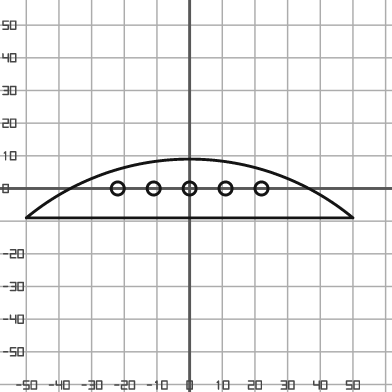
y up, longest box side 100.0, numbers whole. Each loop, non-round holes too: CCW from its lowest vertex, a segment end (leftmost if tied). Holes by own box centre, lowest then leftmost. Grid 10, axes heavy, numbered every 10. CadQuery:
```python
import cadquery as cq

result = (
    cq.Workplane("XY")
    .moveTo(-50.0, -9.0)
    .lineTo(50.0, -9.0)
    .threePointArc((0.0, 9.0), (-50.0, -9.0))
    .close()
    .moveTo(-22.0, 0.0)
    .circle(2.0)
    .moveTo(-11.0, 0.0)
    .circle(2.0)
    .moveTo(0.0, 0.0)
    .circle(2.0)
    .moveTo(11.0, 0.0)
    .circle(2.0)
    .moveTo(22.0, 0.0)
    .circle(2.0)
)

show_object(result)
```